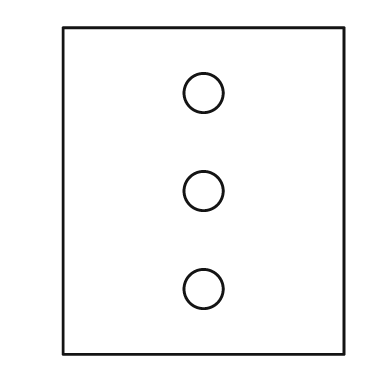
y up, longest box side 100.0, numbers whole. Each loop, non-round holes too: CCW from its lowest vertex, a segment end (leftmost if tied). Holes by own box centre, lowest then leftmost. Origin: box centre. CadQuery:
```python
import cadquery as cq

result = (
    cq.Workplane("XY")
    .moveTo(-43.0, -50.0)
    .lineTo(43.0, -50.0)
    .lineTo(43.0, 50.0)
    .lineTo(-43.0, 50.0)
    .close()
    .moveTo(0.0, -30.0)
    .circle(6.0)
    .moveTo(0.0, 0.0)
    .circle(6.0)
    .moveTo(0.0, 30.0)
    .circle(6.0)
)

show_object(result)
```